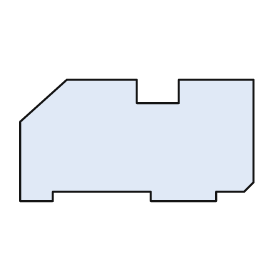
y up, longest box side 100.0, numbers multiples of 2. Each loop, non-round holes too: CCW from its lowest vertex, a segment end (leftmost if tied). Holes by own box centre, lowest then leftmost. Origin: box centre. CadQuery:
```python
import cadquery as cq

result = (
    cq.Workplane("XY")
    .moveTo(-50.0, -26.0)
    .lineTo(-36.0, -26.0)
    .lineTo(-36.0, -22.0)
    .lineTo(6.0, -22.0)
    .lineTo(6.0, -26.0)
    .lineTo(34.0, -26.0)
    .lineTo(34.0, -22.0)
    .lineTo(46.0, -22.0)
    .lineTo(50.0, -18.0)
    .lineTo(50.0, 26.0)
    .lineTo(18.0, 26.0)
    .lineTo(18.0, 16.0)
    .lineTo(0.0, 16.0)
    .lineTo(0.0, 26.0)
    .lineTo(-30.0, 26.0)
    .lineTo(-50.0, 8.0)
    .close()
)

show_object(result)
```